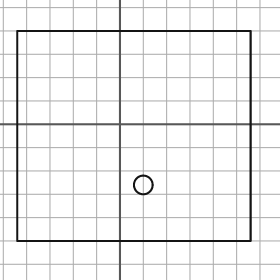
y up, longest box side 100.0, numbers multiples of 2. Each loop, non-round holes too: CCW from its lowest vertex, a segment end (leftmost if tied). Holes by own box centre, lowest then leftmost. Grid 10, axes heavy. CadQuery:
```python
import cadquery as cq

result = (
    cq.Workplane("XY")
    .moveTo(-44.0, -50.0)
    .lineTo(56.0, -50.0)
    .lineTo(56.0, 40.0)
    .lineTo(-44.0, 40.0)
    .close()
    .moveTo(10.0, -26.0)
    .circle(4.0)
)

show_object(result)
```